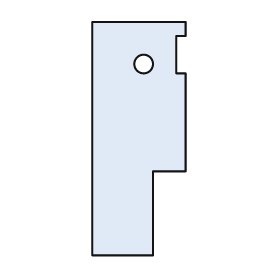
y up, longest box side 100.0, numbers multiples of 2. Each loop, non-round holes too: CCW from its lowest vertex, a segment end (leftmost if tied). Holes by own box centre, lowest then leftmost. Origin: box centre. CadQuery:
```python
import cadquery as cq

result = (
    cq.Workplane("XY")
    .moveTo(-20.0, -50.0)
    .lineTo(6.0, -50.0)
    .lineTo(6.0, -14.0)
    .lineTo(20.0, -14.0)
    .lineTo(20.0, 28.0)
    .lineTo(16.0, 28.0)
    .lineTo(16.0, 44.0)
    .lineTo(20.0, 44.0)
    .lineTo(20.0, 50.0)
    .lineTo(-20.0, 50.0)
    .close()
    .moveTo(2.0, 32.0)
    .circle(4.0)
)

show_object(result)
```